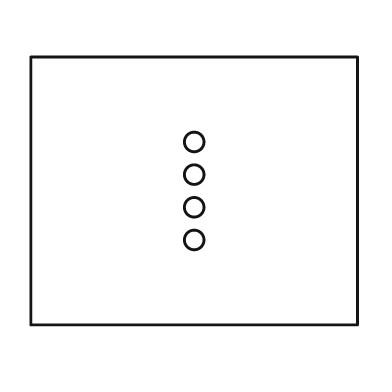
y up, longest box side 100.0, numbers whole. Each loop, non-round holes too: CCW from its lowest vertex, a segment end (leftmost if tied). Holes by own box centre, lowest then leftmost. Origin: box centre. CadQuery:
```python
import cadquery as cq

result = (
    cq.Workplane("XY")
    .moveTo(-50.0, -41.0)
    .lineTo(50.0, -41.0)
    .lineTo(50.0, 41.0)
    .lineTo(-50.0, 41.0)
    .close()
    .moveTo(0.0, -15.0)
    .circle(3.0)
    .moveTo(0.0, -5.0)
    .circle(3.0)
    .moveTo(0.0, 5.0)
    .circle(3.0)
    .moveTo(0.0, 15.0)
    .circle(3.0)
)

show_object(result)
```